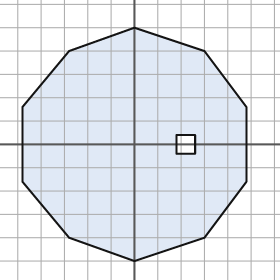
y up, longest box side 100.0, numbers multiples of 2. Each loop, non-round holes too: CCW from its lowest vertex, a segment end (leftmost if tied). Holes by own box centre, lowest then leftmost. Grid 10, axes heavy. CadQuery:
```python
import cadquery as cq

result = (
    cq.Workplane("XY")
    .moveTo(0.0, -50.0)
    .lineTo(30.0, -40.0)
    .lineTo(48.0, -16.0)
    .lineTo(48.0, 16.0)
    .lineTo(30.0, 40.0)
    .lineTo(0.0, 50.0)
    .lineTo(-28.0, 40.0)
    .lineTo(-48.0, 16.0)
    .lineTo(-48.0, -16.0)
    .lineTo(-28.0, -40.0)
    .close()
    .moveTo(18.0, -4.0)
    .lineTo(26.0, -4.0)
    .lineTo(26.0, 4.0)
    .lineTo(18.0, 4.0)
    .close()
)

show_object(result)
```